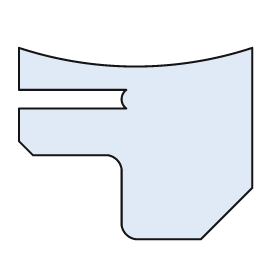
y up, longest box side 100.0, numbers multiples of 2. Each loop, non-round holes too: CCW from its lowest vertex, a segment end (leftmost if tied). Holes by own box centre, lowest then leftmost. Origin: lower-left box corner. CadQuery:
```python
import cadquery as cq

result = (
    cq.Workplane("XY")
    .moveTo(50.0, 0.0)
    .lineTo(78.0, 0.0)
    .lineTo(100.0, 22.0)
    .lineTo(100.0, 82.0)
    .threePointArc((50.0, 74.0), (0.0, 82.0))
    .lineTo(0.0, 64.0)
    .lineTo(46.0, 64.0)
    .threePointArc((44.0, 60.0), (46.0, 56.0))
    .lineTo(0.0, 56.0)
    .lineTo(0.0, 42.0)
    .lineTo(6.0, 36.0)
    .lineTo(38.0, 36.0)
    .threePointArc((42.0, 34.0), (44.0, 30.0))
    .lineTo(44.0, 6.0)
    .threePointArc((46.0, 2.0), (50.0, 0.0))
    .close()
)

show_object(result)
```